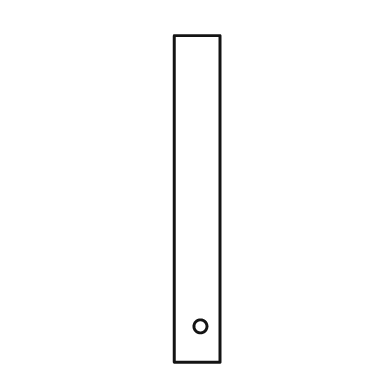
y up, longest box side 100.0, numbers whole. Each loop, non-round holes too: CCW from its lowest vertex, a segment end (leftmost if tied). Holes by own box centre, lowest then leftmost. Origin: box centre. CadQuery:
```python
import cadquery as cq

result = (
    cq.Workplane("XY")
    .moveTo(-7.0, -50.0)
    .lineTo(7.0, -50.0)
    .lineTo(7.0, 50.0)
    .lineTo(-7.0, 50.0)
    .close()
    .moveTo(1.0, -39.0)
    .circle(2.0)
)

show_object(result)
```